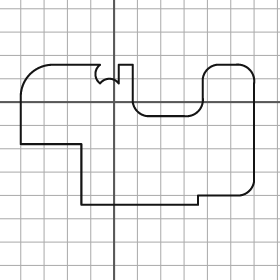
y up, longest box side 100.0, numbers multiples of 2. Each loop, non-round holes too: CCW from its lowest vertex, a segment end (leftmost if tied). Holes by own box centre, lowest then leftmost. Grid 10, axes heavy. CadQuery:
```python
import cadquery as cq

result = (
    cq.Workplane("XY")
    .moveTo(-14.0, -44.0)
    .lineTo(36.0, -44.0)
    .lineTo(36.0, -40.0)
    .lineTo(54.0, -40.0)
    .threePointArc((58.0, -38.0), (60.0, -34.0))
    .lineTo(60.0, 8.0)
    .threePointArc((58.0, 14.0), (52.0, 16.0))
    .lineTo(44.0, 16.0)
    .threePointArc((40.0, 14.0), (38.0, 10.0))
    .lineTo(38.0, 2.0)
    .threePointArc((36.0, -4.0), (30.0, -6.0))
    .lineTo(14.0, -6.0)
    .threePointArc((10.0, -4.0), (8.0, 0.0))
    .lineTo(8.0, 16.0)
    .lineTo(2.0, 16.0)
    .lineTo(2.0, 8.0)
    .threePointArc((-2.0, 10.0), (-6.0, 8.0))
    .threePointArc((-8.0, 12.0), (-6.0, 16.0))
    .lineTo(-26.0, 16.0)
    .threePointArc((-36.0, 12.0), (-40.0, 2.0))
    .lineTo(-40.0, -18.0)
    .lineTo(-14.0, -18.0)
    .close()
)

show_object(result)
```